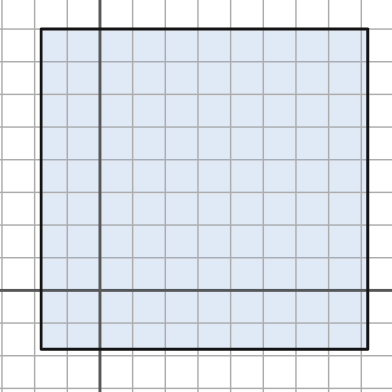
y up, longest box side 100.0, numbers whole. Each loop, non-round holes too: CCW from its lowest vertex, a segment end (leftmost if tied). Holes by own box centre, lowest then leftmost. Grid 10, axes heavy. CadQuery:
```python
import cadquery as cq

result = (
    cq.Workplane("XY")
    .moveTo(-18.0, -18.0)
    .lineTo(82.0, -18.0)
    .lineTo(82.0, 80.0)
    .lineTo(-18.0, 80.0)
    .close()
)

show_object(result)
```